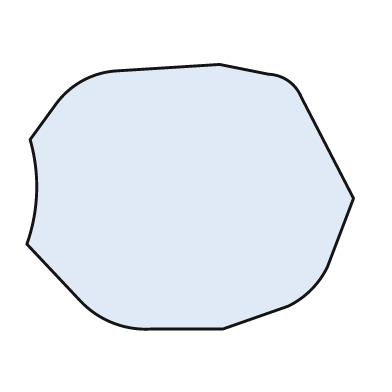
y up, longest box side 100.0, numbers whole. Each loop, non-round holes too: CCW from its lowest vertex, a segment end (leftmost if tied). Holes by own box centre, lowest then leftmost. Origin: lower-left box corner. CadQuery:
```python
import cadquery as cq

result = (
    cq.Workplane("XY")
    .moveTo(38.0, 0.0)
    .lineTo(60.0, 0.0)
    .lineTo(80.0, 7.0)
    .threePointArc((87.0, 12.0), (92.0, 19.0))
    .lineTo(100.0, 40.0)
    .lineTo(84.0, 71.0)
    .threePointArc((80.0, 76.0), (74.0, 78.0))
    .lineTo(59.0, 81.0)
    .lineTo(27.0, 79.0)
    .threePointArc((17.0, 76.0), (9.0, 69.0))
    .lineTo(1.0, 58.0)
    .threePointArc((3.0, 42.0), (0.0, 26.0))
    .lineTo(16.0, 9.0)
    .threePointArc((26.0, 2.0), (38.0, 0.0))
    .close()
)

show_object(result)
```